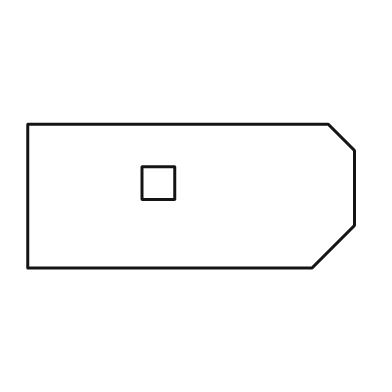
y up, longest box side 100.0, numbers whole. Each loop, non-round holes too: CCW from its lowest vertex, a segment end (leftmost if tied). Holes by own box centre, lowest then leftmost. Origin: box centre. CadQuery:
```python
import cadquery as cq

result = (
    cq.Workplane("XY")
    .moveTo(-50.0, -22.0)
    .lineTo(37.0, -22.0)
    .lineTo(50.0, -9.0)
    .lineTo(50.0, 14.0)
    .lineTo(42.0, 22.0)
    .lineTo(-50.0, 22.0)
    .close()
    .moveTo(-15.0, -1.0)
    .lineTo(-5.0, -1.0)
    .lineTo(-5.0, 9.0)
    .lineTo(-15.0, 9.0)
    .close()
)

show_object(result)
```